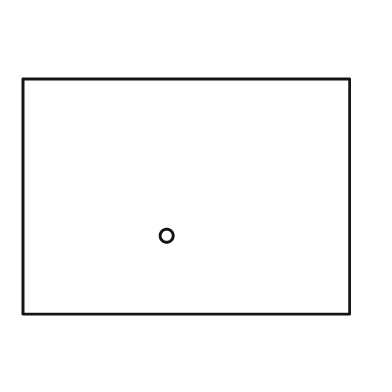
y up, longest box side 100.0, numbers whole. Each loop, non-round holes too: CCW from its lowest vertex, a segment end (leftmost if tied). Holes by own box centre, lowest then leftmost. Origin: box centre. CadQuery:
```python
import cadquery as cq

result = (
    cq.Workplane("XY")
    .moveTo(-50.0, -36.0)
    .lineTo(50.0, -36.0)
    .lineTo(50.0, 36.0)
    .lineTo(-50.0, 36.0)
    .close()
    .moveTo(-6.0, -12.0)
    .circle(2.0)
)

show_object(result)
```